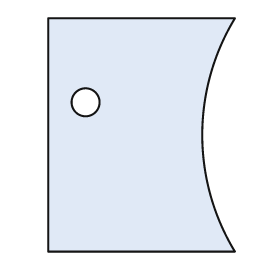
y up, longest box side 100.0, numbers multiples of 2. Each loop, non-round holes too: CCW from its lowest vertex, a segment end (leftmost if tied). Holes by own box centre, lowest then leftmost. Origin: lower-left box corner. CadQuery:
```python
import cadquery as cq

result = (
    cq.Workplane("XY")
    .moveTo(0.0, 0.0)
    .lineTo(80.0, 0.0)
    .threePointArc((66.0, 50.0), (80.0, 100.0))
    .lineTo(0.0, 100.0)
    .close()
    .moveTo(16.0, 64.0)
    .circle(6.0)
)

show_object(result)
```